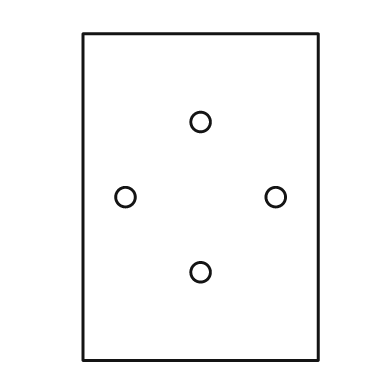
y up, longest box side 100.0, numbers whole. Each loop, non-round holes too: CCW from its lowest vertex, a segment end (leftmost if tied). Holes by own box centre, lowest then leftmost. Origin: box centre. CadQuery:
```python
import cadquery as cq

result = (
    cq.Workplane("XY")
    .moveTo(-36.0, -50.0)
    .lineTo(36.0, -50.0)
    .lineTo(36.0, 50.0)
    .lineTo(-36.0, 50.0)
    .close()
    .moveTo(0.0, -23.0)
    .circle(3.0)
    .moveTo(-23.0, 0.0)
    .circle(3.0)
    .moveTo(23.0, 0.0)
    .circle(3.0)
    .moveTo(0.0, 23.0)
    .circle(3.0)
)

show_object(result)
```